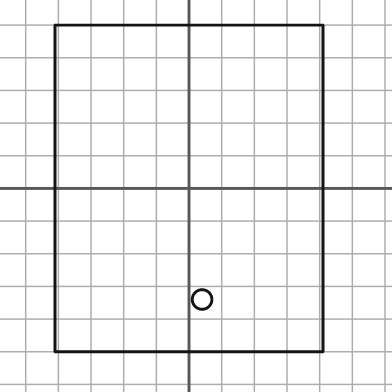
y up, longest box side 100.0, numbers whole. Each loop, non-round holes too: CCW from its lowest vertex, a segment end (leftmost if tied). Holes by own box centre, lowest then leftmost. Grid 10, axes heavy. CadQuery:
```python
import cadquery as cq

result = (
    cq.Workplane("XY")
    .moveTo(-41.0, -50.0)
    .lineTo(41.0, -50.0)
    .lineTo(41.0, 50.0)
    .lineTo(-41.0, 50.0)
    .close()
    .moveTo(4.0, -34.0)
    .circle(3.0)
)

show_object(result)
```